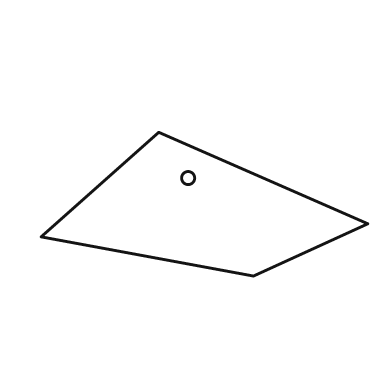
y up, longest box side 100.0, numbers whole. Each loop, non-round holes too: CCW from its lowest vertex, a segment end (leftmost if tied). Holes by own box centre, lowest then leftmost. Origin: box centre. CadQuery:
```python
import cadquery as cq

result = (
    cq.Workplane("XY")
    .moveTo(15.0, -22.0)
    .lineTo(50.0, -6.0)
    .lineTo(-14.0, 22.0)
    .lineTo(-50.0, -10.0)
    .close()
    .moveTo(-5.0, 8.0)
    .circle(2.0)
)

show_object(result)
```